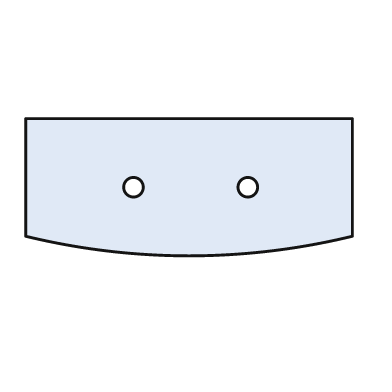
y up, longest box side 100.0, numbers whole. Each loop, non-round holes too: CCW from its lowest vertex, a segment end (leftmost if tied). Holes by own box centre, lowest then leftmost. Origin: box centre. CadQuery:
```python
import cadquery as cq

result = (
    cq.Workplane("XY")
    .moveTo(-50.0, -15.0)
    .threePointArc((0.0, -21.0), (50.0, -15.0))
    .lineTo(50.0, 21.0)
    .lineTo(-50.0, 21.0)
    .close()
    .moveTo(-17.0, 0.0)
    .circle(3.0)
    .moveTo(18.0, 0.0)
    .circle(3.0)
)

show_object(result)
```